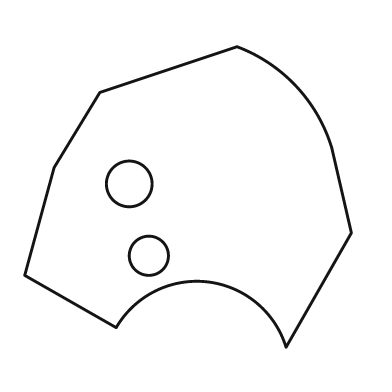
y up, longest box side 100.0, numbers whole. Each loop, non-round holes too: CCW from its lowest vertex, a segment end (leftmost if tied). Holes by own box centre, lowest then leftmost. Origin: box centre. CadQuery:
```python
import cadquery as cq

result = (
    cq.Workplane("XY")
    .moveTo(30.0, -46.0)
    .lineTo(50.0, -11.0)
    .lineTo(44.0, 15.0)
    .threePointArc((33.0, 34.0), (15.0, 46.0))
    .lineTo(-27.0, 32.0)
    .lineTo(-41.0, 9.0)
    .lineTo(-50.0, -24.0)
    .lineTo(-22.0, -40.0)
    .threePointArc((6.0, -26.0), (30.0, -46.0))
    .close()
    .moveTo(-12.0, -18.0)
    .circle(6.0)
    .moveTo(-18.0, 4.0)
    .circle(7.0)
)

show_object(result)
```